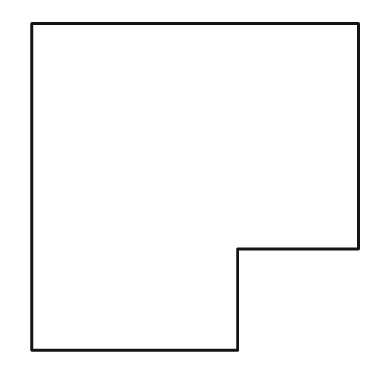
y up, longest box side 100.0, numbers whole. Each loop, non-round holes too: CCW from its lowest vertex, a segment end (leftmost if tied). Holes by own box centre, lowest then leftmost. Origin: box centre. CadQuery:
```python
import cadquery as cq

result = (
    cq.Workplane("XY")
    .moveTo(-50.0, -50.0)
    .lineTo(13.0, -50.0)
    .lineTo(13.0, -19.0)
    .lineTo(50.0, -19.0)
    .lineTo(50.0, 50.0)
    .lineTo(-50.0, 50.0)
    .close()
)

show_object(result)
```